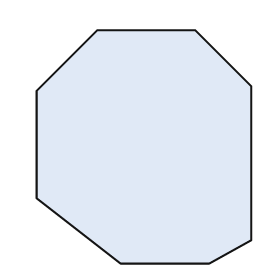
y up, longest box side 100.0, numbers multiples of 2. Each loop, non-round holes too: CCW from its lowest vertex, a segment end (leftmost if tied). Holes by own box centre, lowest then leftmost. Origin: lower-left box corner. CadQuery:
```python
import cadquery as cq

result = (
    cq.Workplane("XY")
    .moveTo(36.0, 0.0)
    .lineTo(74.0, 0.0)
    .lineTo(92.0, 10.0)
    .lineTo(92.0, 76.0)
    .lineTo(68.0, 100.0)
    .lineTo(26.0, 100.0)
    .lineTo(0.0, 74.0)
    .lineTo(0.0, 28.0)
    .close()
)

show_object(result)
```